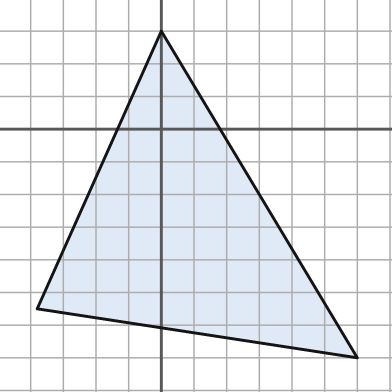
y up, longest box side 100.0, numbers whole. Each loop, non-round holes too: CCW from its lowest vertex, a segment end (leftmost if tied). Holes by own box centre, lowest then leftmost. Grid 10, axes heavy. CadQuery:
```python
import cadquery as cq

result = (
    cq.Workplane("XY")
    .moveTo(60.0, -70.0)
    .lineTo(0.0, 30.0)
    .lineTo(-38.0, -55.0)
    .close()
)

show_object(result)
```